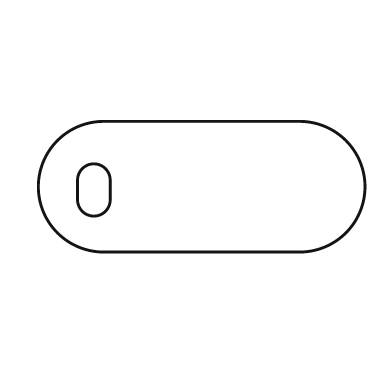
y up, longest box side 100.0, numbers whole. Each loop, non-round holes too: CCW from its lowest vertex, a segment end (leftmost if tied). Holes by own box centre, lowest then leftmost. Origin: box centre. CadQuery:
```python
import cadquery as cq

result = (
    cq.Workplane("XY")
    .moveTo(-30.0, -20.0)
    .lineTo(30.0, -20.0)
    .threePointArc((50.0, 0.0), (30.0, 20.0))
    .lineTo(-30.0, 20.0)
    .threePointArc((-50.0, 0.0), (-30.0, -20.0))
    .close()
    .moveTo(-38.0, -4.0)
    .threePointArc((-33.0, -9.0), (-28.0, -4.0))
    .lineTo(-28.0, 2.0)
    .threePointArc((-33.0, 7.0), (-38.0, 2.0))
    .close()
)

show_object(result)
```